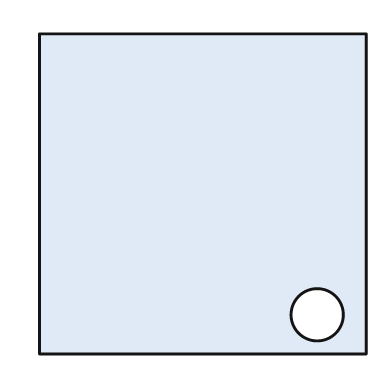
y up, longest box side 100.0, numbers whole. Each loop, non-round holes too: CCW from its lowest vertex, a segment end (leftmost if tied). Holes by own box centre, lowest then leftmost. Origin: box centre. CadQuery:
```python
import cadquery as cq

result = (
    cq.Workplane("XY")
    .moveTo(-50.0, -49.0)
    .lineTo(50.0, -49.0)
    .lineTo(50.0, 49.0)
    .lineTo(-50.0, 49.0)
    .close()
    .moveTo(35.0, -37.0)
    .circle(8.0)
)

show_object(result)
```